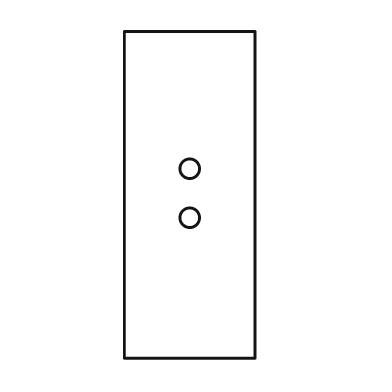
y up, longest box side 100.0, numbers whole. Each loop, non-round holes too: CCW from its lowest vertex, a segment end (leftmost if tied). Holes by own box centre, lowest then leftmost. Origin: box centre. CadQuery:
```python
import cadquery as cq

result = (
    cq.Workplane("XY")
    .moveTo(-20.0, -50.0)
    .lineTo(20.0, -50.0)
    .lineTo(20.0, 50.0)
    .lineTo(-20.0, 50.0)
    .close()
    .moveTo(0.0, -7.0)
    .circle(3.0)
    .moveTo(0.0, 8.0)
    .circle(3.0)
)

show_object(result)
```